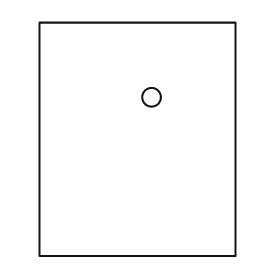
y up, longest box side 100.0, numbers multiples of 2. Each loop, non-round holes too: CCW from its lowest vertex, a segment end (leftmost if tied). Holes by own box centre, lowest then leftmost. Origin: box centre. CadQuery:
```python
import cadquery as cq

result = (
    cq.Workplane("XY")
    .moveTo(-42.0, -50.0)
    .lineTo(42.0, -50.0)
    .lineTo(42.0, 50.0)
    .lineTo(-42.0, 50.0)
    .close()
    .moveTo(6.0, 18.0)
    .circle(4.0)
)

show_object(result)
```